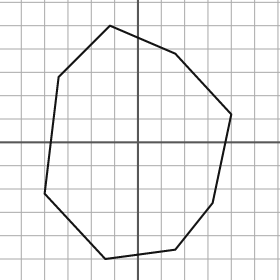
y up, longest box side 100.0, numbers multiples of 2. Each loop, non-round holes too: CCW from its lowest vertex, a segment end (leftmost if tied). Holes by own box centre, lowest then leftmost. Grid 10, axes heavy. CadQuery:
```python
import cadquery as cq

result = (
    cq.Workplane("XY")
    .moveTo(-14.0, -50.0)
    .lineTo(16.0, -46.0)
    .lineTo(32.0, -26.0)
    .lineTo(40.0, 12.0)
    .lineTo(16.0, 38.0)
    .lineTo(-12.0, 50.0)
    .lineTo(-34.0, 28.0)
    .lineTo(-40.0, -22.0)
    .close()
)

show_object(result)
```